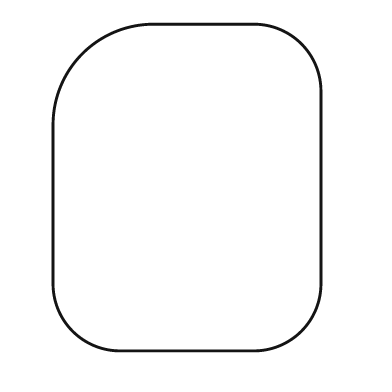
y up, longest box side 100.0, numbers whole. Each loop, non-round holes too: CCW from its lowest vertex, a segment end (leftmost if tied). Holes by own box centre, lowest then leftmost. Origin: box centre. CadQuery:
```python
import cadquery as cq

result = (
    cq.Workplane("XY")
    .moveTo(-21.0, -50.0)
    .lineTo(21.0, -50.0)
    .threePointArc((35.0, -44.0), (41.0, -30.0))
    .lineTo(41.0, 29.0)
    .threePointArc((35.0, 44.0), (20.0, 50.0))
    .lineTo(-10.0, 50.0)
    .threePointArc((-32.0, 41.0), (-41.0, 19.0))
    .lineTo(-41.0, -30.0)
    .threePointArc((-35.0, -44.0), (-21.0, -50.0))
    .close()
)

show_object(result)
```